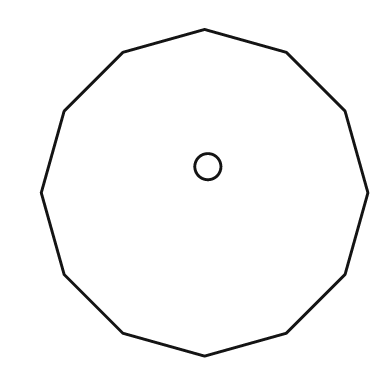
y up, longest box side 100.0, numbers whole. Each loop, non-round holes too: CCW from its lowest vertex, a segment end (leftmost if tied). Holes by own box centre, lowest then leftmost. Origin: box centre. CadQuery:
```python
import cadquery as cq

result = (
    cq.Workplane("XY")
    .moveTo(0.0, -50.0)
    .lineTo(25.0, -43.0)
    .lineTo(43.0, -25.0)
    .lineTo(50.0, 0.0)
    .lineTo(43.0, 25.0)
    .lineTo(25.0, 43.0)
    .lineTo(0.0, 50.0)
    .lineTo(-25.0, 43.0)
    .lineTo(-43.0, 25.0)
    .lineTo(-50.0, 0.0)
    .lineTo(-43.0, -25.0)
    .lineTo(-25.0, -43.0)
    .close()
    .moveTo(1.0, 8.0)
    .circle(4.0)
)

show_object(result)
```